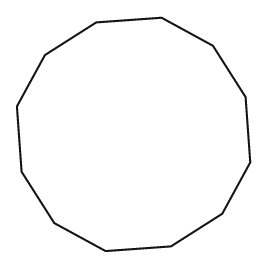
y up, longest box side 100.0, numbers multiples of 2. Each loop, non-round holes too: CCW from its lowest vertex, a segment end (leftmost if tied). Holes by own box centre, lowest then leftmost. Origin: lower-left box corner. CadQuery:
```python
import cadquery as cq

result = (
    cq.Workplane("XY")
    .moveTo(38.0, 0.0)
    .lineTo(66.0, 2.0)
    .lineTo(88.0, 16.0)
    .lineTo(100.0, 38.0)
    .lineTo(98.0, 66.0)
    .lineTo(84.0, 88.0)
    .lineTo(62.0, 100.0)
    .lineTo(34.0, 98.0)
    .lineTo(12.0, 84.0)
    .lineTo(0.0, 62.0)
    .lineTo(2.0, 34.0)
    .lineTo(16.0, 12.0)
    .close()
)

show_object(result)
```